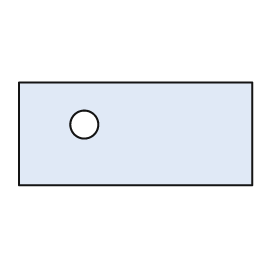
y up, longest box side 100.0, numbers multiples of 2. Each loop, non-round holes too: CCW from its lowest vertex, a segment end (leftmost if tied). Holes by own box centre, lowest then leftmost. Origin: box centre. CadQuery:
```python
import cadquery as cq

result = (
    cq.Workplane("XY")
    .moveTo(-50.0, -22.0)
    .lineTo(50.0, -22.0)
    .lineTo(50.0, 22.0)
    .lineTo(-50.0, 22.0)
    .close()
    .moveTo(-22.0, 4.0)
    .circle(6.0)
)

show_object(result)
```